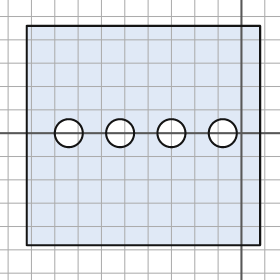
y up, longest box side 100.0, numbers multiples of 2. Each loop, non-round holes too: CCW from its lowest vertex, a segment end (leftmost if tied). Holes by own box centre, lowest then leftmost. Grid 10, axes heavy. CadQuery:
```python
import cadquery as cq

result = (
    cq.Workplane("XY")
    .moveTo(-92.0, -48.0)
    .lineTo(8.0, -48.0)
    .lineTo(8.0, 46.0)
    .lineTo(-92.0, 46.0)
    .close()
    .moveTo(-74.0, 0.0)
    .circle(6.0)
    .moveTo(-52.0, 0.0)
    .circle(6.0)
    .moveTo(-30.0, 0.0)
    .circle(6.0)
    .moveTo(-8.0, 0.0)
    .circle(6.0)
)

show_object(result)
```